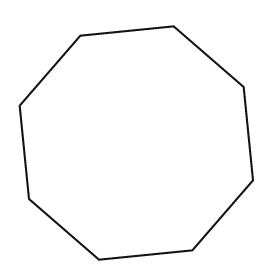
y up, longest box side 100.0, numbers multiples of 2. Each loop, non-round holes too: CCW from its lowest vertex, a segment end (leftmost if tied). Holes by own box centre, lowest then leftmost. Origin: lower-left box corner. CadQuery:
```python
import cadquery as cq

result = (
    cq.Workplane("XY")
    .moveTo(34.0, 0.0)
    .lineTo(74.0, 4.0)
    .lineTo(100.0, 34.0)
    .lineTo(96.0, 74.0)
    .lineTo(66.0, 100.0)
    .lineTo(26.0, 96.0)
    .lineTo(0.0, 66.0)
    .lineTo(4.0, 26.0)
    .close()
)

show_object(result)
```